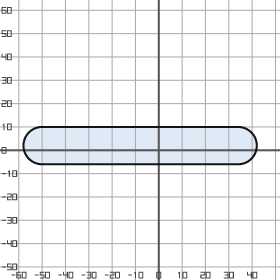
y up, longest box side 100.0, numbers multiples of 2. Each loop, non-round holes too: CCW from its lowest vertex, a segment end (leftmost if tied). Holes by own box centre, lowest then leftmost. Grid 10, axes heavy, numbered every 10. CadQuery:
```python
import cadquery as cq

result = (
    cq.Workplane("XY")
    .moveTo(-50.0, -6.0)
    .lineTo(34.0, -6.0)
    .threePointArc((42.0, 2.0), (34.0, 10.0))
    .lineTo(-50.0, 10.0)
    .threePointArc((-58.0, 2.0), (-50.0, -6.0))
    .close()
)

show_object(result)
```